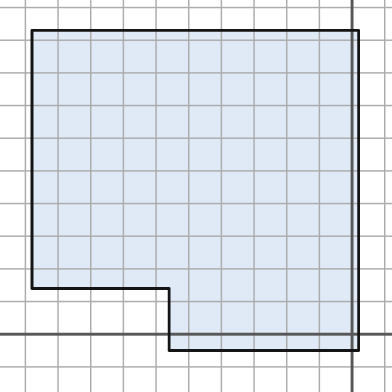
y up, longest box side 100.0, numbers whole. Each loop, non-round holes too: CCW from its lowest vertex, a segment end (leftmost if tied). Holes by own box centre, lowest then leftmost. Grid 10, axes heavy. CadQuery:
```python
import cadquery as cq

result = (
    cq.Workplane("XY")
    .moveTo(-56.0, -5.0)
    .lineTo(2.0, -5.0)
    .lineTo(2.0, 93.0)
    .lineTo(-98.0, 93.0)
    .lineTo(-98.0, 14.0)
    .lineTo(-56.0, 14.0)
    .close()
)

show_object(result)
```